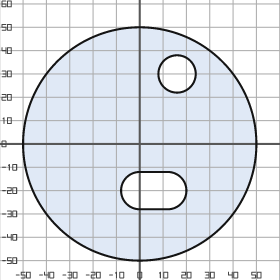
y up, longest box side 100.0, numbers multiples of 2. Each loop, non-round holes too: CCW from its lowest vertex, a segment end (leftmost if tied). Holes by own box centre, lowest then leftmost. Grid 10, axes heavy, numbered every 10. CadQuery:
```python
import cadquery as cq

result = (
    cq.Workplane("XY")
    .moveTo(0.0, 0.0)
    .circle(50.0)
    .moveTo(0.0, -28.0)
    .lineTo(12.0, -28.0)
    .threePointArc((20.0, -20.0), (12.0, -12.0))
    .lineTo(0.0, -12.0)
    .threePointArc((-8.0, -20.0), (0.0, -28.0))
    .close()
    .moveTo(16.0, 30.0)
    .circle(8.0)
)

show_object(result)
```